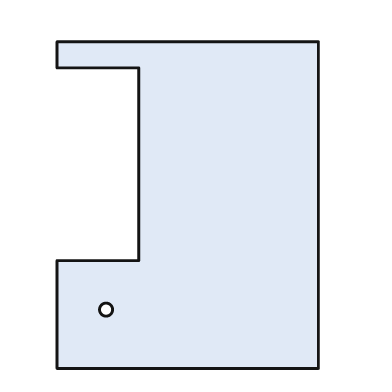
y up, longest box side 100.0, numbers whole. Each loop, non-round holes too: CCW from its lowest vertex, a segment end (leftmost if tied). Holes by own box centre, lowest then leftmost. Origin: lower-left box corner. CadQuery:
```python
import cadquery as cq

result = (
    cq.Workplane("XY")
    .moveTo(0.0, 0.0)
    .lineTo(80.0, 0.0)
    .lineTo(80.0, 100.0)
    .lineTo(0.0, 100.0)
    .lineTo(0.0, 92.0)
    .lineTo(25.0, 92.0)
    .lineTo(25.0, 33.0)
    .lineTo(0.0, 33.0)
    .close()
    .moveTo(15.0, 18.0)
    .circle(2.0)
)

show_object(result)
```